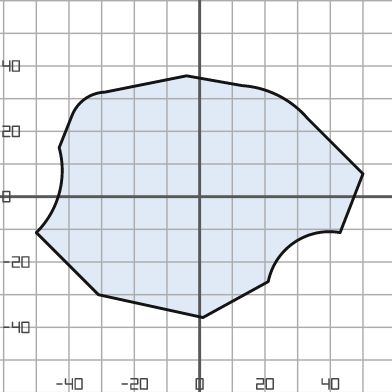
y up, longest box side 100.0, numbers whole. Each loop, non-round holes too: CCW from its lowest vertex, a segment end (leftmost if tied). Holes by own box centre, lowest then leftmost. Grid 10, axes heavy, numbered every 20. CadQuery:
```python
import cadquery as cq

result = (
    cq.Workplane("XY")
    .moveTo(1.0, -37.0)
    .lineTo(21.0, -26.0)
    .threePointArc((29.0, -14.0), (43.0, -11.0))
    .lineTo(50.0, 7.0)
    .lineTo(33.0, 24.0)
    .threePointArc((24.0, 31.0), (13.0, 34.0))
    .lineTo(-4.0, 37.0)
    .lineTo(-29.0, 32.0)
    .threePointArc((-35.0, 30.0), (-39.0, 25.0))
    .lineTo(-43.0, 15.0)
    .threePointArc((-43.0, 1.0), (-50.0, -11.0))
    .lineTo(-31.0, -30.0)
    .close()
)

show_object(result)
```